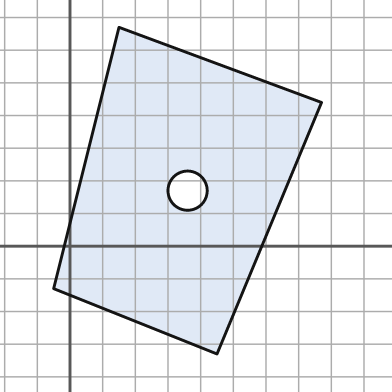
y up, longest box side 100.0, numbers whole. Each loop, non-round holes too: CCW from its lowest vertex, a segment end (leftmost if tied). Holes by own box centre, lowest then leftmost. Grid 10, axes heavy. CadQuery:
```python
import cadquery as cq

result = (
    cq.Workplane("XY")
    .moveTo(45.0, -33.0)
    .lineTo(77.0, 44.0)
    .lineTo(15.0, 67.0)
    .lineTo(-5.0, -13.0)
    .close()
    .moveTo(36.0, 17.0)
    .circle(6.0)
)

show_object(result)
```